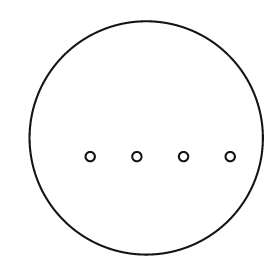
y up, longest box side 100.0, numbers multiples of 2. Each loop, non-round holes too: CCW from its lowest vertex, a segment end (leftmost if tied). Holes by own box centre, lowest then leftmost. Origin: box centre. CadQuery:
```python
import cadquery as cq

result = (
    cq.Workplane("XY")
    .moveTo(0.0, 0.0)
    .circle(50.0)
    .moveTo(-24.0, -8.0)
    .circle(2.0)
    .moveTo(-4.0, -8.0)
    .circle(2.0)
    .moveTo(16.0, -8.0)
    .circle(2.0)
    .moveTo(36.0, -8.0)
    .circle(2.0)
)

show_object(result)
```